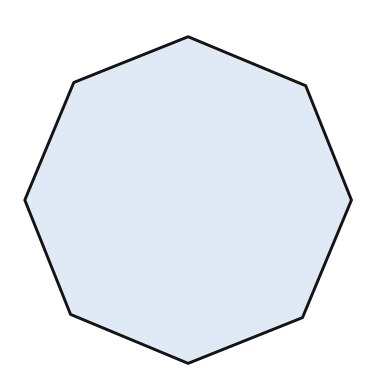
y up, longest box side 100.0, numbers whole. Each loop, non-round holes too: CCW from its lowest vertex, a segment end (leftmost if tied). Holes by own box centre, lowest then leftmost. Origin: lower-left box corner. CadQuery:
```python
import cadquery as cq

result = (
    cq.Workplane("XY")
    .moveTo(50.0, 0.0)
    .lineTo(85.0, 14.0)
    .lineTo(100.0, 50.0)
    .lineTo(86.0, 85.0)
    .lineTo(50.0, 100.0)
    .lineTo(15.0, 86.0)
    .lineTo(0.0, 50.0)
    .lineTo(14.0, 15.0)
    .close()
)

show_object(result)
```